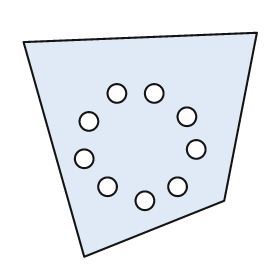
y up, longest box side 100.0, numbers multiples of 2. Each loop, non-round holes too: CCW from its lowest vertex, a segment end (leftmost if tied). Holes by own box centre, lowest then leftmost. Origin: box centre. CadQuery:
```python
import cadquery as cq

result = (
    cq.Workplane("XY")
    .moveTo(-24.0, -48.0)
    .lineTo(36.0, -24.0)
    .lineTo(50.0, 48.0)
    .lineTo(-50.0, 44.0)
    .close()
    .moveTo(2.0, -24.0)
    .circle(4.0)
    .moveTo(-14.0, -18.0)
    .circle(4.0)
    .moveTo(16.0, -18.0)
    .circle(4.0)
    .moveTo(-24.0, -6.0)
    .circle(4.0)
    .moveTo(24.0, -2.0)
    .circle(4.0)
    .moveTo(-22.0, 10.0)
    .circle(4.0)
    .moveTo(20.0, 12.0)
    .circle(4.0)
    .moveTo(-10.0, 22.0)
    .circle(4.0)
    .moveTo(6.0, 22.0)
    .circle(4.0)
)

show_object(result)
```